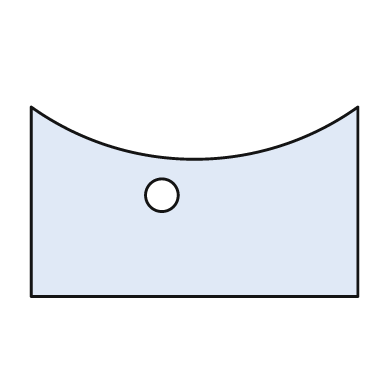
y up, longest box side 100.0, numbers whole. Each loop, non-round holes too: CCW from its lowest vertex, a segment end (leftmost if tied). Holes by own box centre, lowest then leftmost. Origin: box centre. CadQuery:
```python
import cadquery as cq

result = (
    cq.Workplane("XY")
    .moveTo(-50.0, -29.0)
    .lineTo(50.0, -29.0)
    .lineTo(50.0, 29.0)
    .threePointArc((0.0, 13.0), (-50.0, 29.0))
    .close()
    .moveTo(-10.0, 2.0)
    .circle(5.0)
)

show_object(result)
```